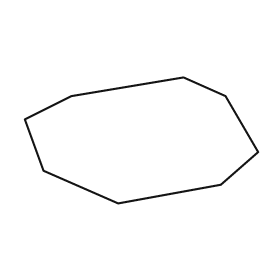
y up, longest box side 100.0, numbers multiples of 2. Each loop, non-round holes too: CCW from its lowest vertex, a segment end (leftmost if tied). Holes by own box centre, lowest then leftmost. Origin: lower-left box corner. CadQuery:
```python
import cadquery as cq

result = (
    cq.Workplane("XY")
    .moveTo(40.0, 0.0)
    .lineTo(84.0, 8.0)
    .lineTo(100.0, 22.0)
    .lineTo(86.0, 46.0)
    .lineTo(68.0, 54.0)
    .lineTo(20.0, 46.0)
    .lineTo(0.0, 36.0)
    .lineTo(8.0, 14.0)
    .close()
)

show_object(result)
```